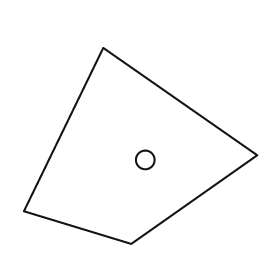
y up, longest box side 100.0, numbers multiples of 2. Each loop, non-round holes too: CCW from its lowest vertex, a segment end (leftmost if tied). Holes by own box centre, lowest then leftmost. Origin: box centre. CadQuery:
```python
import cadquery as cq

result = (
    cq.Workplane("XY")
    .moveTo(-4.0, -42.0)
    .lineTo(50.0, -4.0)
    .lineTo(-16.0, 42.0)
    .lineTo(-50.0, -28.0)
    .close()
    .moveTo(2.0, -6.0)
    .circle(4.0)
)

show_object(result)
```